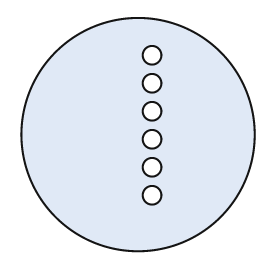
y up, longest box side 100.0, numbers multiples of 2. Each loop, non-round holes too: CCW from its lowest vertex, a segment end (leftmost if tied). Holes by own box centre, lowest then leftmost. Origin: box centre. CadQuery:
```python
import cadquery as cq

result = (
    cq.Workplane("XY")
    .moveTo(0.0, 0.0)
    .circle(50.0)
    .moveTo(6.0, -26.0)
    .circle(4.0)
    .moveTo(6.0, -14.0)
    .circle(4.0)
    .moveTo(6.0, -2.0)
    .circle(4.0)
    .moveTo(6.0, 10.0)
    .circle(4.0)
    .moveTo(6.0, 22.0)
    .circle(4.0)
    .moveTo(6.0, 34.0)
    .circle(4.0)
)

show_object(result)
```